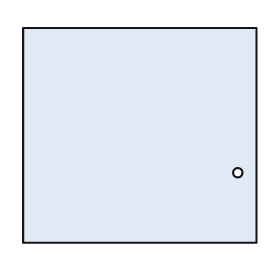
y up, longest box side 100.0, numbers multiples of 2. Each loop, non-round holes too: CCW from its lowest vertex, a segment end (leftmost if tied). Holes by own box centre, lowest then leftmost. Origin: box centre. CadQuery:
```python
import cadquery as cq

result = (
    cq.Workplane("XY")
    .moveTo(-50.0, -46.0)
    .lineTo(50.0, -46.0)
    .lineTo(50.0, 46.0)
    .lineTo(-50.0, 46.0)
    .close()
    .moveTo(42.0, -16.0)
    .circle(2.0)
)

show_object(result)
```